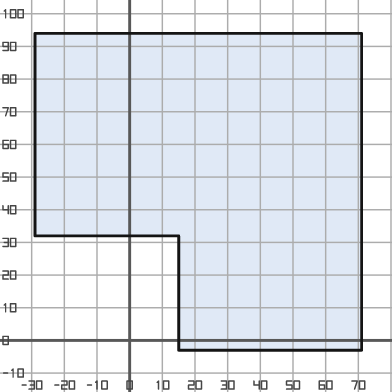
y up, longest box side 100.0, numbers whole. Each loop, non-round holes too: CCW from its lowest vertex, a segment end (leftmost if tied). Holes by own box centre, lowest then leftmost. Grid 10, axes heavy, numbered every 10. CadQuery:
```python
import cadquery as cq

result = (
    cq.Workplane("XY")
    .moveTo(15.0, -3.0)
    .lineTo(71.0, -3.0)
    .lineTo(71.0, 94.0)
    .lineTo(-29.0, 94.0)
    .lineTo(-29.0, 32.0)
    .lineTo(15.0, 32.0)
    .close()
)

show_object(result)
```